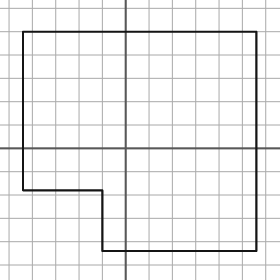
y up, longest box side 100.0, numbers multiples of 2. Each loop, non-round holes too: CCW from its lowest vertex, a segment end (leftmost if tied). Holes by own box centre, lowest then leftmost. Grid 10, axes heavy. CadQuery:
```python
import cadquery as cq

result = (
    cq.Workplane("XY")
    .moveTo(-10.0, -44.0)
    .lineTo(56.0, -44.0)
    .lineTo(56.0, 50.0)
    .lineTo(-44.0, 50.0)
    .lineTo(-44.0, -18.0)
    .lineTo(-10.0, -18.0)
    .close()
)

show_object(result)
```